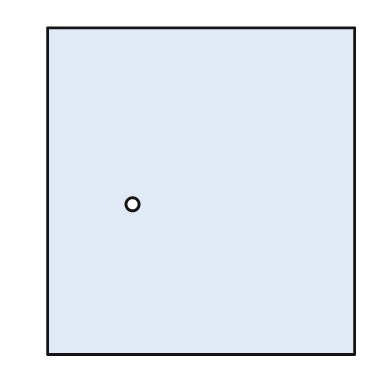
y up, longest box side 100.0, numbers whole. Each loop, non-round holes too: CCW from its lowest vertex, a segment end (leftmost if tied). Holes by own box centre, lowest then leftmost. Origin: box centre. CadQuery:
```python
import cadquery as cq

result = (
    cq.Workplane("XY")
    .moveTo(-47.0, -50.0)
    .lineTo(47.0, -50.0)
    .lineTo(47.0, 50.0)
    .lineTo(-47.0, 50.0)
    .close()
    .moveTo(-21.0, -4.0)
    .circle(2.0)
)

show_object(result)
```